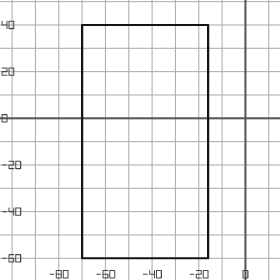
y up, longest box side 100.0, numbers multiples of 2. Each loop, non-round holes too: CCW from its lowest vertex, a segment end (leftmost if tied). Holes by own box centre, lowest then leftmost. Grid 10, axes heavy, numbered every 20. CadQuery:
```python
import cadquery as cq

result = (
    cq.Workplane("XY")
    .moveTo(-70.0, -60.0)
    .lineTo(-16.0, -60.0)
    .lineTo(-16.0, 40.0)
    .lineTo(-70.0, 40.0)
    .close()
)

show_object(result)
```